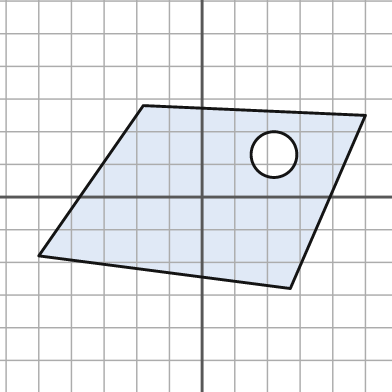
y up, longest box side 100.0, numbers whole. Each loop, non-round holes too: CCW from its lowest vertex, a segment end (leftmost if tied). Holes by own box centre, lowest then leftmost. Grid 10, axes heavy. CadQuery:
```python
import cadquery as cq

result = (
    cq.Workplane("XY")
    .moveTo(27.0, -28.0)
    .lineTo(50.0, 25.0)
    .lineTo(-18.0, 28.0)
    .lineTo(-50.0, -18.0)
    .close()
    .moveTo(22.0, 13.0)
    .circle(7.0)
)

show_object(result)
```